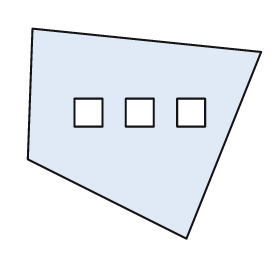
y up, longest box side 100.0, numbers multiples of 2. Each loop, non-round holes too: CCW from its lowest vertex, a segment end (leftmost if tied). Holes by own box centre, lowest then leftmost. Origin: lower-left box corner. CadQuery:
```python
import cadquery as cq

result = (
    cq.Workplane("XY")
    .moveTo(68.0, 0.0)
    .lineTo(100.0, 80.0)
    .lineTo(2.0, 90.0)
    .lineTo(0.0, 34.0)
    .close()
    .moveTo(20.0, 48.0)
    .lineTo(32.0, 48.0)
    .lineTo(32.0, 60.0)
    .lineTo(20.0, 60.0)
    .close()
    .moveTo(42.0, 48.0)
    .lineTo(54.0, 48.0)
    .lineTo(54.0, 60.0)
    .lineTo(42.0, 60.0)
    .close()
    .moveTo(64.0, 48.0)
    .lineTo(76.0, 48.0)
    .lineTo(76.0, 60.0)
    .lineTo(64.0, 60.0)
    .close()
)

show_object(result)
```